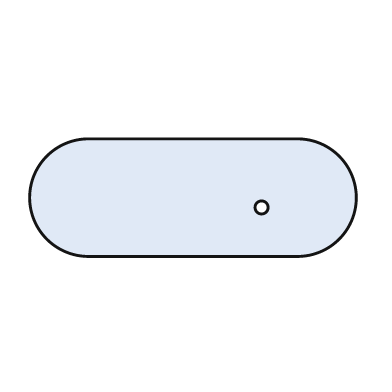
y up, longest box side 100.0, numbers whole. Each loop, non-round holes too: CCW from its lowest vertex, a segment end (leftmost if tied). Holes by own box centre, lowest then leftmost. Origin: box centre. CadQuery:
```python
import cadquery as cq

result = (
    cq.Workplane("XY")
    .moveTo(-32.0, -18.0)
    .lineTo(32.0, -18.0)
    .threePointArc((50.0, 0.0), (32.0, 18.0))
    .lineTo(-32.0, 18.0)
    .threePointArc((-50.0, 0.0), (-32.0, -18.0))
    .close()
    .moveTo(21.0, -3.0)
    .circle(2.0)
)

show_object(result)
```